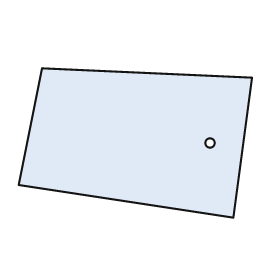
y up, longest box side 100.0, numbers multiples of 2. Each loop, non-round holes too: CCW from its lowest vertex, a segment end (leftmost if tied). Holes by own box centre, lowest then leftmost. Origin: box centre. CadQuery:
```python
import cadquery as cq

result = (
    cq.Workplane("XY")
    .moveTo(42.0, -32.0)
    .lineTo(50.0, 28.0)
    .lineTo(-40.0, 32.0)
    .lineTo(-50.0, -18.0)
    .close()
    .moveTo(32.0, 0.0)
    .circle(2.0)
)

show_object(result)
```